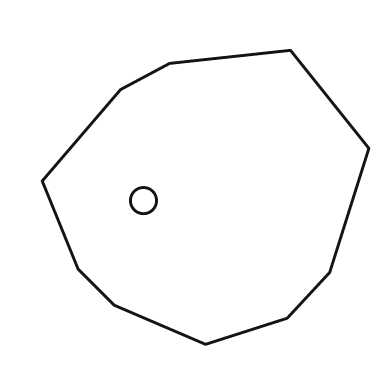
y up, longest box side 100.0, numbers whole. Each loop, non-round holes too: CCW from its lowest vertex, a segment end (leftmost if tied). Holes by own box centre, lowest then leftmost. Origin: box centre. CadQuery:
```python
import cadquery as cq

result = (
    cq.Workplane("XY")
    .moveTo(0.0, -45.0)
    .lineTo(25.0, -37.0)
    .lineTo(38.0, -23.0)
    .lineTo(50.0, 15.0)
    .lineTo(26.0, 45.0)
    .lineTo(-11.0, 41.0)
    .lineTo(-26.0, 33.0)
    .lineTo(-50.0, 5.0)
    .lineTo(-39.0, -22.0)
    .lineTo(-28.0, -33.0)
    .close()
    .moveTo(-19.0, -1.0)
    .circle(4.0)
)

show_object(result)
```